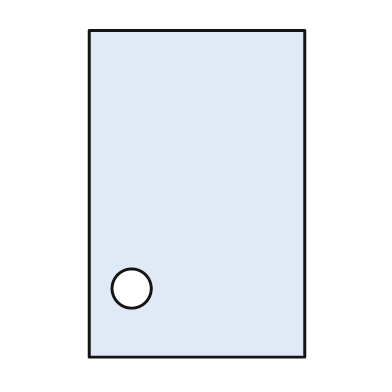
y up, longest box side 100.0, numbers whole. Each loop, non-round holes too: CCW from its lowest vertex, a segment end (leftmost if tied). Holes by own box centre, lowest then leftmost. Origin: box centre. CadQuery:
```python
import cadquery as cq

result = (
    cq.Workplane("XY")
    .moveTo(-33.0, -50.0)
    .lineTo(33.0, -50.0)
    .lineTo(33.0, 50.0)
    .lineTo(-33.0, 50.0)
    .close()
    .moveTo(-20.0, -29.0)
    .circle(6.0)
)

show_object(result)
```